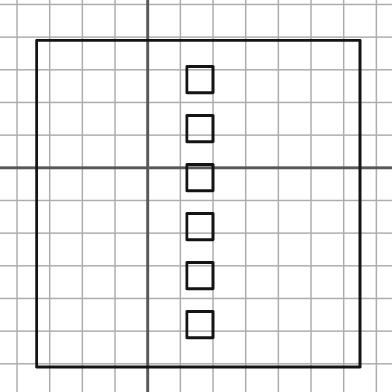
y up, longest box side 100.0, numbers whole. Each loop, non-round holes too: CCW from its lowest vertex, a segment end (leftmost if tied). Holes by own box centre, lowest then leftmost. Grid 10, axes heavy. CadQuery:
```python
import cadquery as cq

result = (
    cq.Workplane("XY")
    .moveTo(-34.0, -61.0)
    .lineTo(65.0, -61.0)
    .lineTo(65.0, 39.0)
    .lineTo(-34.0, 39.0)
    .close()
    .moveTo(12.0, -52.0)
    .lineTo(20.0, -52.0)
    .lineTo(20.0, -44.0)
    .lineTo(12.0, -44.0)
    .close()
    .moveTo(12.0, -37.0)
    .lineTo(20.0, -37.0)
    .lineTo(20.0, -29.0)
    .lineTo(12.0, -29.0)
    .close()
    .moveTo(12.0, -22.0)
    .lineTo(20.0, -22.0)
    .lineTo(20.0, -14.0)
    .lineTo(12.0, -14.0)
    .close()
    .moveTo(12.0, -7.0)
    .lineTo(20.0, -7.0)
    .lineTo(20.0, 1.0)
    .lineTo(12.0, 1.0)
    .close()
    .moveTo(12.0, 8.0)
    .lineTo(20.0, 8.0)
    .lineTo(20.0, 16.0)
    .lineTo(12.0, 16.0)
    .close()
    .moveTo(12.0, 23.0)
    .lineTo(20.0, 23.0)
    .lineTo(20.0, 31.0)
    .lineTo(12.0, 31.0)
    .close()
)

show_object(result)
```